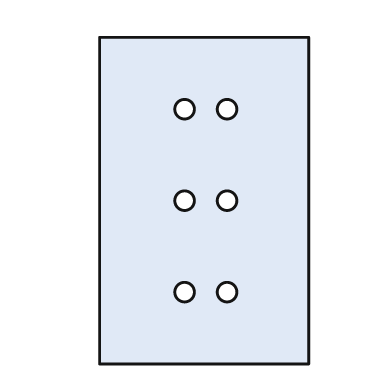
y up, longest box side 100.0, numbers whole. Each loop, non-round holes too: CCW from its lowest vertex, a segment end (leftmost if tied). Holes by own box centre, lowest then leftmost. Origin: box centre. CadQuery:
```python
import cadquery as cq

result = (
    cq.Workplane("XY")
    .moveTo(-32.0, -50.0)
    .lineTo(32.0, -50.0)
    .lineTo(32.0, 50.0)
    .lineTo(-32.0, 50.0)
    .close()
    .moveTo(-6.0, -28.0)
    .circle(3.0)
    .moveTo(7.0, -28.0)
    .circle(3.0)
    .moveTo(-6.0, 0.0)
    .circle(3.0)
    .moveTo(7.0, 0.0)
    .circle(3.0)
    .moveTo(-6.0, 28.0)
    .circle(3.0)
    .moveTo(7.0, 28.0)
    .circle(3.0)
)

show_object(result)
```